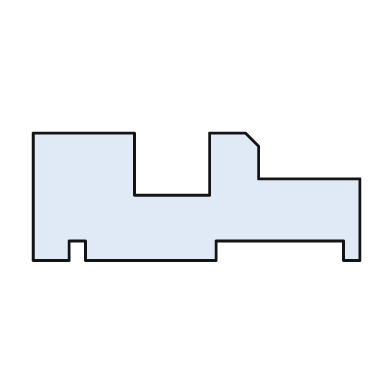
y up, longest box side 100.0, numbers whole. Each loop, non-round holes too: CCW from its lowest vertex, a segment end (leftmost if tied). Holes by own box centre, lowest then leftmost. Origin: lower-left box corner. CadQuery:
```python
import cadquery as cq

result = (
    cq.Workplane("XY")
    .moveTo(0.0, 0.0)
    .lineTo(11.0, 0.0)
    .lineTo(11.0, 6.0)
    .lineTo(16.0, 6.0)
    .lineTo(16.0, 0.0)
    .lineTo(56.0, 0.0)
    .lineTo(56.0, 6.0)
    .lineTo(95.0, 6.0)
    .lineTo(95.0, 0.0)
    .lineTo(100.0, 0.0)
    .lineTo(100.0, 25.0)
    .lineTo(69.0, 25.0)
    .lineTo(69.0, 35.0)
    .lineTo(65.0, 39.0)
    .lineTo(54.0, 39.0)
    .lineTo(54.0, 20.0)
    .lineTo(31.0, 20.0)
    .lineTo(31.0, 39.0)
    .lineTo(0.0, 39.0)
    .close()
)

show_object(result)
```